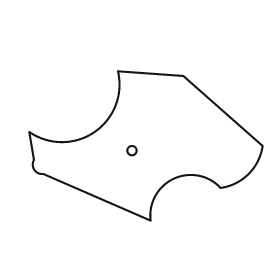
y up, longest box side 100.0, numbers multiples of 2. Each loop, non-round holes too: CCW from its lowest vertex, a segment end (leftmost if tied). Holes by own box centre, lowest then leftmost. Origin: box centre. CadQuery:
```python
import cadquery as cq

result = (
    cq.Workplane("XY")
    .moveTo(2.0, -32.0)
    .threePointArc((12.0, -14.0), (32.0, -18.0))
    .threePointArc((44.0, -12.0), (50.0, 0.0))
    .lineTo(16.0, 30.0)
    .lineTo(-12.0, 32.0)
    .threePointArc((-22.0, 6.0), (-50.0, 6.0))
    .lineTo(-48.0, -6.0)
    .threePointArc((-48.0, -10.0), (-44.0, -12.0))
    .close()
    .moveTo(-6.0, -2.0)
    .circle(2.0)
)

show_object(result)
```